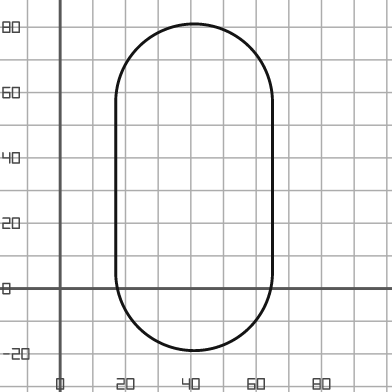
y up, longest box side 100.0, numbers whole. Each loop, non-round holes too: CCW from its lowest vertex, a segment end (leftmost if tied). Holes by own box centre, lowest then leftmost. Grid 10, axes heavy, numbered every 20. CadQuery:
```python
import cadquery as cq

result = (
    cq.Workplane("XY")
    .moveTo(17.0, 5.0)
    .threePointArc((41.0, -19.0), (65.0, 5.0))
    .lineTo(65.0, 57.0)
    .threePointArc((41.0, 81.0), (17.0, 57.0))
    .close()
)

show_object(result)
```